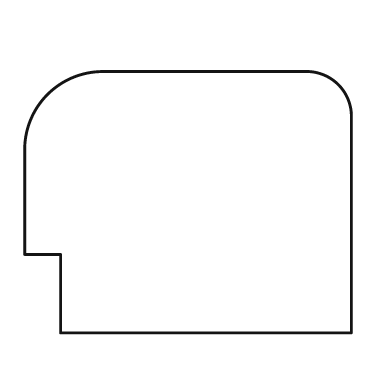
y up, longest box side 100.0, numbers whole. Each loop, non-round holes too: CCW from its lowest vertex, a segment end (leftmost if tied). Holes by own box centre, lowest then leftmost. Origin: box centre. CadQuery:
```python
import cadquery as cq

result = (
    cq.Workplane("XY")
    .moveTo(-39.0, -40.0)
    .lineTo(50.0, -40.0)
    .lineTo(50.0, 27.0)
    .threePointArc((46.0, 36.0), (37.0, 40.0))
    .lineTo(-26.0, 40.0)
    .threePointArc((-43.0, 33.0), (-50.0, 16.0))
    .lineTo(-50.0, -16.0)
    .lineTo(-39.0, -16.0)
    .close()
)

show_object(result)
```